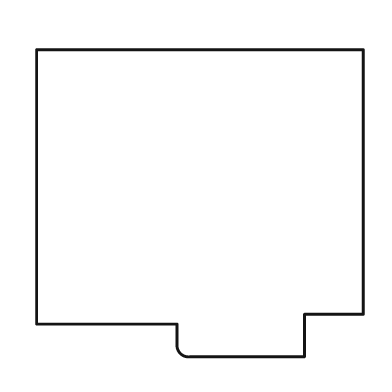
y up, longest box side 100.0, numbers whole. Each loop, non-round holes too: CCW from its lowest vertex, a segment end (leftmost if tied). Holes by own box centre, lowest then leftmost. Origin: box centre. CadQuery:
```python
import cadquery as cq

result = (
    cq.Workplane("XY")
    .moveTo(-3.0, -47.0)
    .lineTo(32.0, -47.0)
    .lineTo(32.0, -34.0)
    .lineTo(50.0, -34.0)
    .lineTo(50.0, 47.0)
    .lineTo(-50.0, 47.0)
    .lineTo(-50.0, -37.0)
    .lineTo(-7.0, -37.0)
    .lineTo(-7.0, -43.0)
    .threePointArc((-6.0, -46.0), (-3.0, -47.0))
    .close()
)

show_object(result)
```